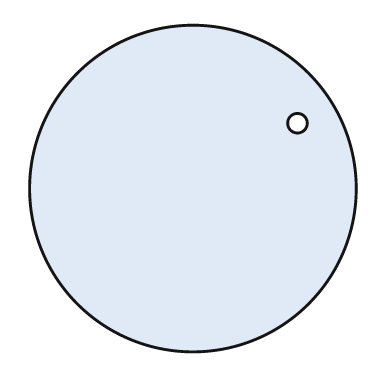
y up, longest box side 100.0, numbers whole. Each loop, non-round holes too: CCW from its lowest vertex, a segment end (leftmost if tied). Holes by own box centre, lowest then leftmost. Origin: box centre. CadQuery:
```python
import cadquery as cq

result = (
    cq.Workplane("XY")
    .moveTo(0.0, 0.0)
    .circle(50.0)
    .moveTo(32.0, 20.0)
    .circle(3.0)
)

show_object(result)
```